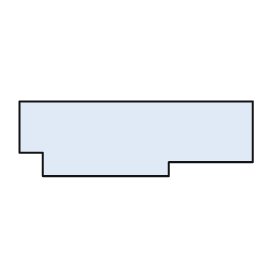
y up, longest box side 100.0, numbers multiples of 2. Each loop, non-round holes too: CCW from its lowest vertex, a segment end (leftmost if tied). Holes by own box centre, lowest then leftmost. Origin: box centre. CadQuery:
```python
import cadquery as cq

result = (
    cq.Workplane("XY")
    .moveTo(-40.0, -16.0)
    .lineTo(14.0, -16.0)
    .lineTo(14.0, -10.0)
    .lineTo(50.0, -10.0)
    .lineTo(50.0, 16.0)
    .lineTo(-50.0, 16.0)
    .lineTo(-50.0, -6.0)
    .lineTo(-40.0, -6.0)
    .close()
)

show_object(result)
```